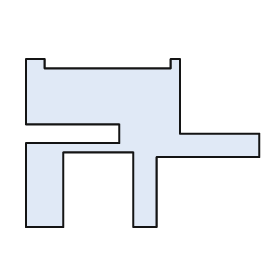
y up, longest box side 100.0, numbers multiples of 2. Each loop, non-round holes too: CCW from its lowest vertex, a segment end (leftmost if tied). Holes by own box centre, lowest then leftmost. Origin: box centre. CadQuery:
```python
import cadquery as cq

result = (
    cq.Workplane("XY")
    .moveTo(-50.0, -36.0)
    .lineTo(-34.0, -36.0)
    .lineTo(-34.0, -4.0)
    .lineTo(-4.0, -4.0)
    .lineTo(-4.0, -36.0)
    .lineTo(6.0, -36.0)
    .lineTo(6.0, -6.0)
    .lineTo(50.0, -6.0)
    .lineTo(50.0, 4.0)
    .lineTo(16.0, 4.0)
    .lineTo(16.0, 36.0)
    .lineTo(12.0, 36.0)
    .lineTo(12.0, 32.0)
    .lineTo(-42.0, 32.0)
    .lineTo(-42.0, 36.0)
    .lineTo(-50.0, 36.0)
    .lineTo(-50.0, 8.0)
    .lineTo(-10.0, 8.0)
    .lineTo(-10.0, 0.0)
    .lineTo(-50.0, 0.0)
    .close()
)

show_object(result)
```